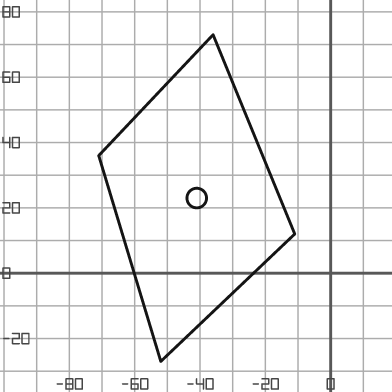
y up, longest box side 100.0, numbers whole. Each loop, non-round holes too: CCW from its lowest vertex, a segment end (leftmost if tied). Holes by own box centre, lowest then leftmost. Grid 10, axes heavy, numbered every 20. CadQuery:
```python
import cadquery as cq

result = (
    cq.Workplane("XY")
    .moveTo(-52.0, -27.0)
    .lineTo(-11.0, 12.0)
    .lineTo(-36.0, 73.0)
    .lineTo(-71.0, 36.0)
    .close()
    .moveTo(-41.0, 23.0)
    .circle(3.0)
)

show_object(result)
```